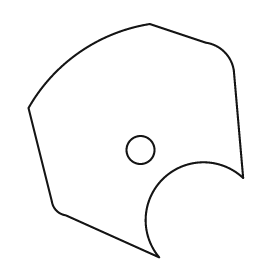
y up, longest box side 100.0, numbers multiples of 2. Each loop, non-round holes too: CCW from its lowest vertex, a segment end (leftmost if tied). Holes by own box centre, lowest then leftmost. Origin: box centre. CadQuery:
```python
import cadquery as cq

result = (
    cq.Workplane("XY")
    .moveTo(10.0, -50.0)
    .threePointArc((12.0, -16.0), (46.0, -16.0))
    .lineTo(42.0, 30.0)
    .threePointArc((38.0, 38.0), (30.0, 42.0))
    .lineTo(6.0, 50.0)
    .threePointArc((-24.0, 38.0), (-46.0, 14.0))
    .lineTo(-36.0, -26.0)
    .threePointArc((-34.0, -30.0), (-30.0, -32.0))
    .close()
    .moveTo(2.0, -4.0)
    .circle(6.0)
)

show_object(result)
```